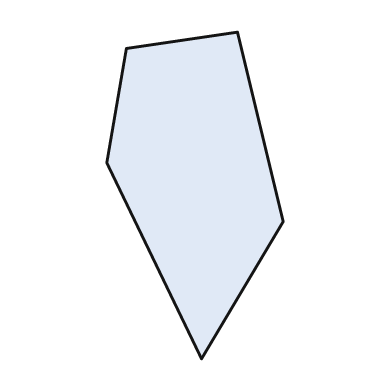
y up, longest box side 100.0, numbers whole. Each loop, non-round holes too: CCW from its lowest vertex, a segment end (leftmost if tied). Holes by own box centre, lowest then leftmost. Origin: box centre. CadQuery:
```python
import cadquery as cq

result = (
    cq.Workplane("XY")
    .moveTo(2.0, -50.0)
    .lineTo(27.0, -8.0)
    .lineTo(13.0, 50.0)
    .lineTo(-21.0, 45.0)
    .lineTo(-27.0, 10.0)
    .close()
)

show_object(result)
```